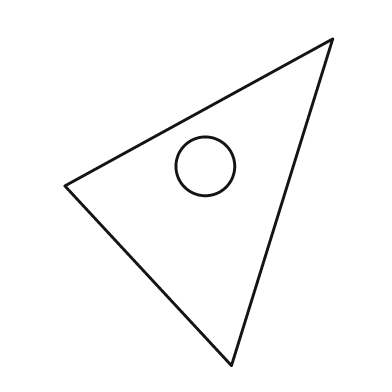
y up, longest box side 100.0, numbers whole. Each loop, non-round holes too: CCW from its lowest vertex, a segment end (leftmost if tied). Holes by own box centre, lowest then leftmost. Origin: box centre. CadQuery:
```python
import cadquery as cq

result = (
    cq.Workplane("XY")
    .moveTo(10.0, -50.0)
    .lineTo(41.0, 50.0)
    .lineTo(-41.0, 5.0)
    .close()
    .moveTo(2.0, 11.0)
    .circle(9.0)
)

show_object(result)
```